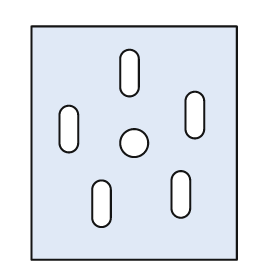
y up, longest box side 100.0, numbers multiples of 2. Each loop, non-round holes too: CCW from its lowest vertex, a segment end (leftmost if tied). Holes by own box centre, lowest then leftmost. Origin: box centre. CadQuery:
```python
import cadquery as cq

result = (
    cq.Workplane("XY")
    .moveTo(-44.0, -50.0)
    .lineTo(44.0, -50.0)
    .lineTo(44.0, 50.0)
    .lineTo(-44.0, 50.0)
    .close()
    .moveTo(-18.0, -32.0)
    .threePointArc((-14.0, -36.0), (-10.0, -32.0))
    .lineTo(-10.0, -20.0)
    .threePointArc((-14.0, -16.0), (-18.0, -20.0))
    .close()
    .moveTo(16.0, -28.0)
    .threePointArc((20.0, -32.0), (24.0, -28.0))
    .lineTo(24.0, -16.0)
    .threePointArc((20.0, -12.0), (16.0, -16.0))
    .close()
    .moveTo(0.0, 0.0)
    .circle(6.0)
    .moveTo(-32.0, 0.0)
    .threePointArc((-28.0, -4.0), (-24.0, 0.0))
    .lineTo(-24.0, 12.0)
    .threePointArc((-28.0, 16.0), (-32.0, 12.0))
    .close()
    .moveTo(22.0, 6.0)
    .threePointArc((26.0, 2.0), (30.0, 6.0))
    .lineTo(30.0, 18.0)
    .threePointArc((26.0, 22.0), (22.0, 18.0))
    .close()
    .moveTo(-6.0, 24.0)
    .threePointArc((-2.0, 20.0), (2.0, 24.0))
    .lineTo(2.0, 36.0)
    .threePointArc((-2.0, 40.0), (-6.0, 36.0))
    .close()
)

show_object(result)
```